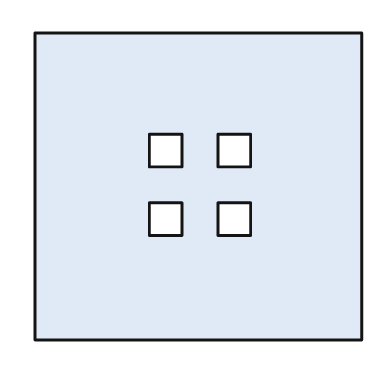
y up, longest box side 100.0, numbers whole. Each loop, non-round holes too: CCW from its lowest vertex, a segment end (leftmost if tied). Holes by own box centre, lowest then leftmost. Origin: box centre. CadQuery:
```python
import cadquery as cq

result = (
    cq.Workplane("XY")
    .moveTo(-50.0, -47.0)
    .lineTo(50.0, -47.0)
    .lineTo(50.0, 47.0)
    .lineTo(-50.0, 47.0)
    .close()
    .moveTo(-15.0, -15.0)
    .lineTo(-5.0, -15.0)
    .lineTo(-5.0, -5.0)
    .lineTo(-15.0, -5.0)
    .close()
    .moveTo(6.0, -15.0)
    .lineTo(16.0, -15.0)
    .lineTo(16.0, -5.0)
    .lineTo(6.0, -5.0)
    .close()
    .moveTo(-15.0, 6.0)
    .lineTo(-5.0, 6.0)
    .lineTo(-5.0, 16.0)
    .lineTo(-15.0, 16.0)
    .close()
    .moveTo(6.0, 6.0)
    .lineTo(16.0, 6.0)
    .lineTo(16.0, 16.0)
    .lineTo(6.0, 16.0)
    .close()
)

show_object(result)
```